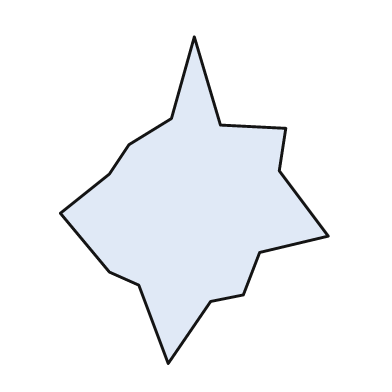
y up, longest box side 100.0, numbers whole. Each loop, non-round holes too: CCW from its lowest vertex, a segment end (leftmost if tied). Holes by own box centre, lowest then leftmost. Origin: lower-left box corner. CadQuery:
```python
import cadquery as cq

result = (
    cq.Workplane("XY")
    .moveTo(33.0, 0.0)
    .lineTo(46.0, 19.0)
    .lineTo(56.0, 21.0)
    .lineTo(61.0, 34.0)
    .lineTo(82.0, 39.0)
    .lineTo(67.0, 59.0)
    .lineTo(69.0, 72.0)
    .lineTo(49.0, 73.0)
    .lineTo(41.0, 100.0)
    .lineTo(34.0, 75.0)
    .lineTo(21.0, 67.0)
    .lineTo(15.0, 58.0)
    .lineTo(0.0, 46.0)
    .lineTo(15.0, 28.0)
    .lineTo(24.0, 24.0)
    .close()
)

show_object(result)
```